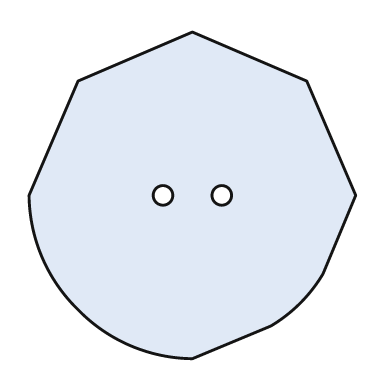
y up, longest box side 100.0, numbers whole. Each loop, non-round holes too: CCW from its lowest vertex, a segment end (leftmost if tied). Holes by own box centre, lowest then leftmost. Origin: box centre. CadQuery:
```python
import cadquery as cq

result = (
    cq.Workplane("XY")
    .moveTo(0.0, -50.0)
    .lineTo(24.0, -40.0)
    .threePointArc((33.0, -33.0), (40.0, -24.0))
    .lineTo(50.0, 0.0)
    .lineTo(35.0, 35.0)
    .lineTo(0.0, 50.0)
    .lineTo(-35.0, 35.0)
    .lineTo(-50.0, 0.0)
    .threePointArc((-46.0, -19.0), (-35.0, -35.0))
    .threePointArc((-19.0, -46.0), (0.0, -50.0))
    .close()
    .moveTo(-9.0, 0.0)
    .circle(3.0)
    .moveTo(9.0, 0.0)
    .circle(3.0)
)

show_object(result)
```